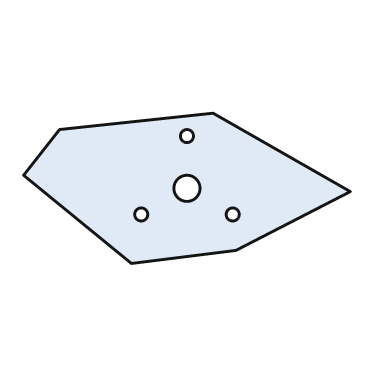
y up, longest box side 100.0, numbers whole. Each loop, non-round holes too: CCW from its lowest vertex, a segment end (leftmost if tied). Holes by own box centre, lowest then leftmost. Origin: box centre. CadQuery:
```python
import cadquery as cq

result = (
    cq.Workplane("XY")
    .moveTo(-17.0, -23.0)
    .lineTo(15.0, -19.0)
    .lineTo(50.0, -1.0)
    .lineTo(8.0, 23.0)
    .lineTo(-39.0, 18.0)
    .lineTo(-50.0, 4.0)
    .close()
    .moveTo(-14.0, -8.0)
    .circle(2.0)
    .moveTo(14.0, -8.0)
    .circle(2.0)
    .moveTo(0.0, 0.0)
    .circle(4.0)
    .moveTo(0.0, 16.0)
    .circle(2.0)
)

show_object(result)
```